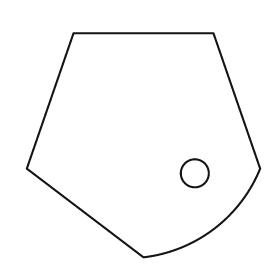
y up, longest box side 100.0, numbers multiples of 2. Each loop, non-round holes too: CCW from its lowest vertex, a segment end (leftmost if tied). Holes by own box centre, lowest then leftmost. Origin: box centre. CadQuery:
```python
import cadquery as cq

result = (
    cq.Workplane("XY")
    .moveTo(0.0, -48.0)
    .threePointArc((30.0, -36.0), (50.0, -10.0))
    .lineTo(30.0, 48.0)
    .lineTo(-30.0, 48.0)
    .lineTo(-50.0, -10.0)
    .close()
    .moveTo(22.0, -12.0)
    .circle(6.0)
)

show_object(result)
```